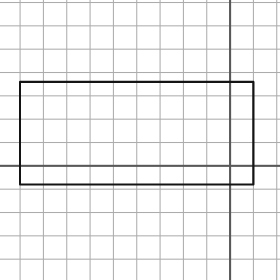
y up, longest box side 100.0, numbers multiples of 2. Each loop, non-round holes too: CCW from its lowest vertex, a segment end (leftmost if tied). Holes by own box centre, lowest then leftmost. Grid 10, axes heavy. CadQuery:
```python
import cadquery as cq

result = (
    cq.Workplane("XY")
    .moveTo(-90.0, -8.0)
    .lineTo(10.0, -8.0)
    .lineTo(10.0, 36.0)
    .lineTo(-90.0, 36.0)
    .close()
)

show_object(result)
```